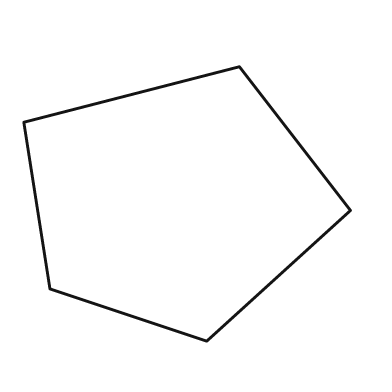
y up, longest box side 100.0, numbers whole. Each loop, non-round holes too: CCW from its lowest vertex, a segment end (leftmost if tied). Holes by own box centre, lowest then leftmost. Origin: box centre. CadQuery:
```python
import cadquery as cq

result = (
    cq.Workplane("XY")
    .moveTo(6.0, -42.0)
    .lineTo(50.0, -2.0)
    .lineTo(16.0, 42.0)
    .lineTo(-50.0, 25.0)
    .lineTo(-42.0, -26.0)
    .close()
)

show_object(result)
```